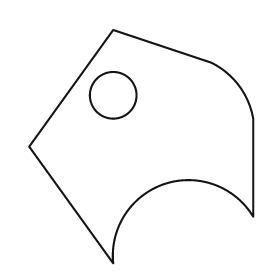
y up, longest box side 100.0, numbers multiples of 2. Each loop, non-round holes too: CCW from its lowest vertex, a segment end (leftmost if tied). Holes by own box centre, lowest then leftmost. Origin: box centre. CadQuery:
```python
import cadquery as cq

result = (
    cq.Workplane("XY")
    .moveTo(-12.0, -50.0)
    .threePointArc((10.0, -16.0), (48.0, -30.0))
    .lineTo(48.0, 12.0)
    .threePointArc((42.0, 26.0), (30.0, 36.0))
    .lineTo(-12.0, 50.0)
    .lineTo(-48.0, 0.0)
    .close()
    .moveTo(-12.0, 22.0)
    .circle(10.0)
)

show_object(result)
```